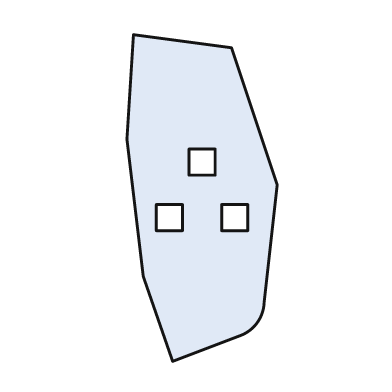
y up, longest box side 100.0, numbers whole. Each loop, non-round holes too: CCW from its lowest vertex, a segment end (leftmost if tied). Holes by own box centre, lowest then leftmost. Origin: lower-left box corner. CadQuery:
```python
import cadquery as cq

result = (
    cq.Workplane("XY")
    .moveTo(14.0, 0.0)
    .lineTo(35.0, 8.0)
    .threePointArc((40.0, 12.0), (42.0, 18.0))
    .lineTo(46.0, 54.0)
    .lineTo(32.0, 96.0)
    .lineTo(2.0, 100.0)
    .lineTo(0.0, 68.0)
    .lineTo(5.0, 26.0)
    .close()
    .moveTo(9.0, 40.0)
    .lineTo(17.0, 40.0)
    .lineTo(17.0, 48.0)
    .lineTo(9.0, 48.0)
    .close()
    .moveTo(29.0, 40.0)
    .lineTo(37.0, 40.0)
    .lineTo(37.0, 48.0)
    .lineTo(29.0, 48.0)
    .close()
    .moveTo(19.0, 57.0)
    .lineTo(27.0, 57.0)
    .lineTo(27.0, 65.0)
    .lineTo(19.0, 65.0)
    .close()
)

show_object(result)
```